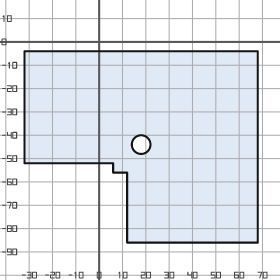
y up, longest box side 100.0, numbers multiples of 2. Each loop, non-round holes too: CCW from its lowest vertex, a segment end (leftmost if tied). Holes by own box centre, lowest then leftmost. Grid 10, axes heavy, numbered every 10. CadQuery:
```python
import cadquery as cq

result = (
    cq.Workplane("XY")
    .moveTo(12.0, -86.0)
    .lineTo(68.0, -86.0)
    .lineTo(68.0, -4.0)
    .lineTo(-32.0, -4.0)
    .lineTo(-32.0, -52.0)
    .lineTo(6.0, -52.0)
    .lineTo(6.0, -56.0)
    .lineTo(12.0, -56.0)
    .close()
    .moveTo(18.0, -44.0)
    .circle(4.0)
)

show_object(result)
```